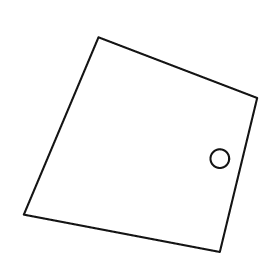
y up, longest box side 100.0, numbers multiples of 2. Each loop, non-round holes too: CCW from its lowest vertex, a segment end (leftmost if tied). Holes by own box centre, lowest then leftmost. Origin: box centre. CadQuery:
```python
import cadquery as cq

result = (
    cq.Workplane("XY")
    .moveTo(34.0, -46.0)
    .lineTo(50.0, 20.0)
    .lineTo(-18.0, 46.0)
    .lineTo(-50.0, -30.0)
    .close()
    .moveTo(34.0, -6.0)
    .circle(4.0)
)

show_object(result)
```